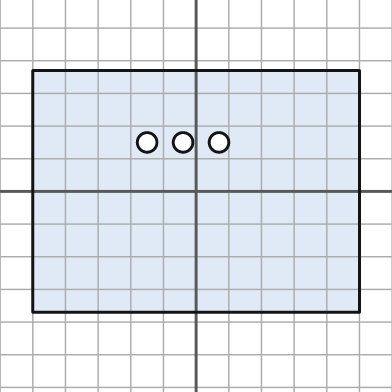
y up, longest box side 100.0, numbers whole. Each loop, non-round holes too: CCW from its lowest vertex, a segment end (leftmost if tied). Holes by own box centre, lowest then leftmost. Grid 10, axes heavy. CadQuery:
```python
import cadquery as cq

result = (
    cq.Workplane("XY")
    .moveTo(-50.0, -37.0)
    .lineTo(50.0, -37.0)
    .lineTo(50.0, 37.0)
    .lineTo(-50.0, 37.0)
    .close()
    .moveTo(-15.0, 15.0)
    .circle(3.0)
    .moveTo(-4.0, 15.0)
    .circle(3.0)
    .moveTo(7.0, 15.0)
    .circle(3.0)
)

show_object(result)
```